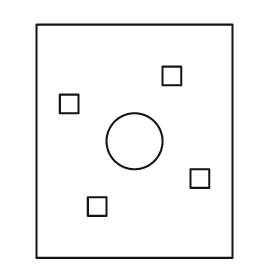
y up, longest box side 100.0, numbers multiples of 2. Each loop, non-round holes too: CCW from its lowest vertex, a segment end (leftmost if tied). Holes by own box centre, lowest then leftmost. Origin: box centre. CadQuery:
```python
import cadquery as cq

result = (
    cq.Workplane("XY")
    .moveTo(-42.0, -50.0)
    .lineTo(42.0, -50.0)
    .lineTo(42.0, 50.0)
    .lineTo(-42.0, 50.0)
    .close()
    .moveTo(-20.0, -32.0)
    .lineTo(-12.0, -32.0)
    .lineTo(-12.0, -24.0)
    .lineTo(-20.0, -24.0)
    .close()
    .moveTo(24.0, -20.0)
    .lineTo(32.0, -20.0)
    .lineTo(32.0, -12.0)
    .lineTo(24.0, -12.0)
    .close()
    .moveTo(0.0, 0.0)
    .circle(12.0)
    .moveTo(-32.0, 12.0)
    .lineTo(-24.0, 12.0)
    .lineTo(-24.0, 20.0)
    .lineTo(-32.0, 20.0)
    .close()
    .moveTo(12.0, 24.0)
    .lineTo(20.0, 24.0)
    .lineTo(20.0, 32.0)
    .lineTo(12.0, 32.0)
    .close()
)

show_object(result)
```